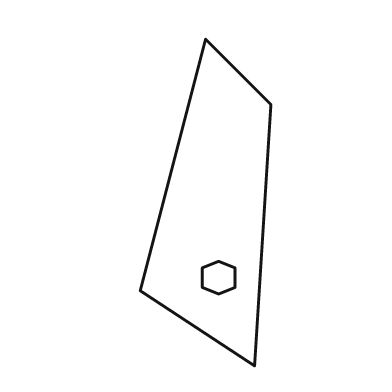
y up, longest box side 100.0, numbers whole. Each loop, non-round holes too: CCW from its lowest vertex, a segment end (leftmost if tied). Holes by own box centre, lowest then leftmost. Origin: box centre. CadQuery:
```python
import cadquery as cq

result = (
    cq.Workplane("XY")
    .moveTo(15.0, -50.0)
    .lineTo(20.0, 30.0)
    .lineTo(0.0, 50.0)
    .lineTo(-20.0, -27.0)
    .close()
    .moveTo(4.0, -28.0)
    .lineTo(9.0, -26.0)
    .lineTo(9.0, -20.0)
    .lineTo(4.0, -18.0)
    .lineTo(-1.0, -20.0)
    .lineTo(-1.0, -26.0)
    .close()
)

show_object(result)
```